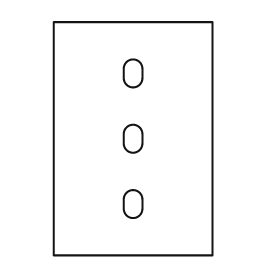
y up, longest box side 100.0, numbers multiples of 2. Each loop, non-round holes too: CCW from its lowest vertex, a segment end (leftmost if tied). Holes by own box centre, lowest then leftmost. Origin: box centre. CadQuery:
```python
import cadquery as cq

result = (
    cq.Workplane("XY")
    .moveTo(-34.0, -50.0)
    .lineTo(34.0, -50.0)
    .lineTo(34.0, 50.0)
    .lineTo(-34.0, 50.0)
    .close()
    .moveTo(-4.0, -30.0)
    .threePointArc((0.0, -34.0), (4.0, -30.0))
    .lineTo(4.0, -26.0)
    .threePointArc((0.0, -22.0), (-4.0, -26.0))
    .close()
    .moveTo(-4.0, -2.0)
    .threePointArc((0.0, -6.0), (4.0, -2.0))
    .lineTo(4.0, 2.0)
    .threePointArc((0.0, 6.0), (-4.0, 2.0))
    .close()
    .moveTo(-4.0, 26.0)
    .threePointArc((0.0, 22.0), (4.0, 26.0))
    .lineTo(4.0, 30.0)
    .threePointArc((0.0, 34.0), (-4.0, 30.0))
    .close()
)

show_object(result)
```